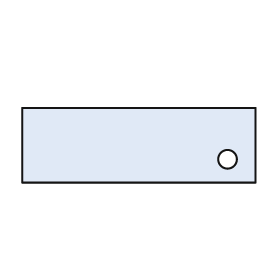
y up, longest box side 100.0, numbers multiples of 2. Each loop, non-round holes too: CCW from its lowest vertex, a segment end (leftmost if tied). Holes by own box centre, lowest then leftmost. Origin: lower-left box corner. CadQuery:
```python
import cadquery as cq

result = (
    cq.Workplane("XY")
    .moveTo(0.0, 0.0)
    .lineTo(100.0, 0.0)
    .lineTo(100.0, 32.0)
    .lineTo(0.0, 32.0)
    .close()
    .moveTo(88.0, 10.0)
    .circle(4.0)
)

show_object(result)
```